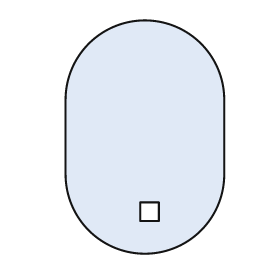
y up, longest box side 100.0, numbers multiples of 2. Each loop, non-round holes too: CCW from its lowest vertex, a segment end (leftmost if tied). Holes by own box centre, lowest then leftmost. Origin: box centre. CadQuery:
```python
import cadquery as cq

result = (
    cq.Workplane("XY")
    .moveTo(-34.0, -16.0)
    .threePointArc((0.0, -50.0), (34.0, -16.0))
    .lineTo(34.0, 16.0)
    .threePointArc((0.0, 50.0), (-34.0, 16.0))
    .close()
    .moveTo(-2.0, -36.0)
    .lineTo(6.0, -36.0)
    .lineTo(6.0, -28.0)
    .lineTo(-2.0, -28.0)
    .close()
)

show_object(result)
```